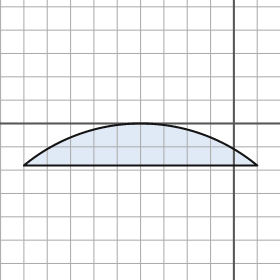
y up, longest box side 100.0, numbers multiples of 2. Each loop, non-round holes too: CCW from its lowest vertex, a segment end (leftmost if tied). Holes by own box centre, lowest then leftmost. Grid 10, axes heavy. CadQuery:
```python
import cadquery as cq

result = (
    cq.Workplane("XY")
    .moveTo(-90.0, -18.0)
    .lineTo(10.0, -18.0)
    .threePointArc((-40.0, 0.0), (-90.0, -18.0))
    .close()
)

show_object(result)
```